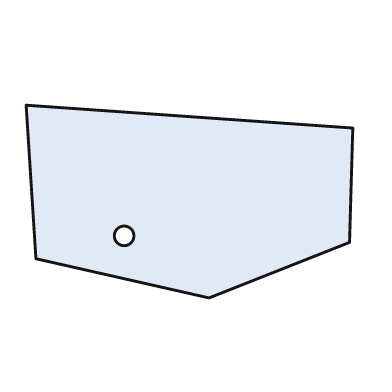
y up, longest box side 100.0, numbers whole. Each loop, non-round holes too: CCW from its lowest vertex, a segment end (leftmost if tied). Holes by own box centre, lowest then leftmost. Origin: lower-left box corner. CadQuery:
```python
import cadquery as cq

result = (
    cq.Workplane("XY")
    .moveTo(56.0, 0.0)
    .lineTo(99.0, 17.0)
    .lineTo(100.0, 52.0)
    .lineTo(0.0, 59.0)
    .lineTo(3.0, 12.0)
    .close()
    .moveTo(30.0, 19.0)
    .circle(3.0)
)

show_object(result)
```